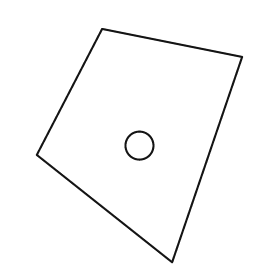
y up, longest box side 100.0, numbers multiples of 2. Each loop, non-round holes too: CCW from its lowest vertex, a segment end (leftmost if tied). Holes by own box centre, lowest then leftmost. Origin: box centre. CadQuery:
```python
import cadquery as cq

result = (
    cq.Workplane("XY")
    .moveTo(14.0, -50.0)
    .lineTo(44.0, 38.0)
    .lineTo(-16.0, 50.0)
    .lineTo(-44.0, -4.0)
    .close()
    .moveTo(0.0, 0.0)
    .circle(6.0)
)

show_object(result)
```